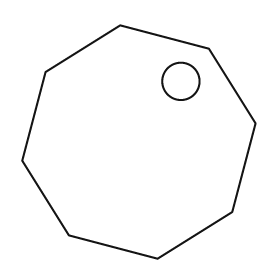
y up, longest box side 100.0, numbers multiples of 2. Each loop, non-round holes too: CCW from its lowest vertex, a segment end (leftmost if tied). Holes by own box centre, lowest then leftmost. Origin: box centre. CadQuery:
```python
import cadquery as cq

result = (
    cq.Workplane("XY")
    .moveTo(8.0, -50.0)
    .lineTo(40.0, -30.0)
    .lineTo(50.0, 8.0)
    .lineTo(30.0, 40.0)
    .lineTo(-8.0, 50.0)
    .lineTo(-40.0, 30.0)
    .lineTo(-50.0, -8.0)
    .lineTo(-30.0, -40.0)
    .close()
    .moveTo(18.0, 26.0)
    .circle(8.0)
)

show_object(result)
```